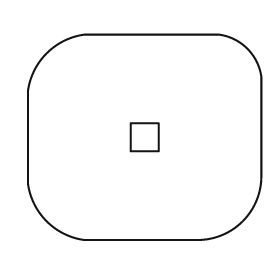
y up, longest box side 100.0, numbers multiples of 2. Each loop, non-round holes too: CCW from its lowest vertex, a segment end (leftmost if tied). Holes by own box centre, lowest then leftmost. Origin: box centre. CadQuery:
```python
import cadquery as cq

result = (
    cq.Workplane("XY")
    .moveTo(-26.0, -44.0)
    .lineTo(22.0, -44.0)
    .threePointArc((42.0, -36.0), (50.0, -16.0))
    .lineTo(50.0, 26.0)
    .threePointArc((44.0, 38.0), (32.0, 44.0))
    .lineTo(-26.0, 44.0)
    .threePointArc((-42.0, 36.0), (-50.0, 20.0))
    .lineTo(-50.0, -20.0)
    .threePointArc((-42.0, -36.0), (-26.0, -44.0))
    .close()
    .moveTo(-6.0, -6.0)
    .lineTo(6.0, -6.0)
    .lineTo(6.0, 6.0)
    .lineTo(-6.0, 6.0)
    .close()
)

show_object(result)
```